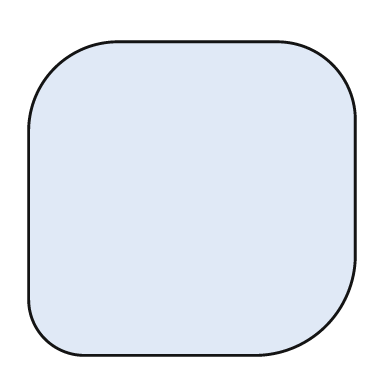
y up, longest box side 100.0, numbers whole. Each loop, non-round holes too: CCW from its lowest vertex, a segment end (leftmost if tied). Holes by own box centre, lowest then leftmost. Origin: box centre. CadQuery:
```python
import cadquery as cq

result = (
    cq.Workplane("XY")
    .moveTo(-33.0, -48.0)
    .lineTo(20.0, -48.0)
    .threePointArc((41.0, -39.0), (50.0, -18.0))
    .lineTo(50.0, 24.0)
    .threePointArc((43.0, 41.0), (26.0, 48.0))
    .lineTo(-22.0, 48.0)
    .threePointArc((-42.0, 40.0), (-50.0, 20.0))
    .lineTo(-50.0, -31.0)
    .threePointArc((-45.0, -43.0), (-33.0, -48.0))
    .close()
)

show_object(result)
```